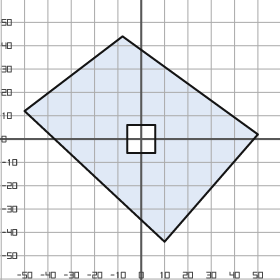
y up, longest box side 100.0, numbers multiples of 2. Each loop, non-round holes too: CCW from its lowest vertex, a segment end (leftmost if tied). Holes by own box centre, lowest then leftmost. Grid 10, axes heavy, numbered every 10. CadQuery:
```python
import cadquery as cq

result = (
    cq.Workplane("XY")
    .moveTo(10.0, -44.0)
    .lineTo(50.0, 2.0)
    .lineTo(-8.0, 44.0)
    .lineTo(-50.0, 12.0)
    .close()
    .moveTo(-6.0, -6.0)
    .lineTo(6.0, -6.0)
    .lineTo(6.0, 6.0)
    .lineTo(-6.0, 6.0)
    .close()
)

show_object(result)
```